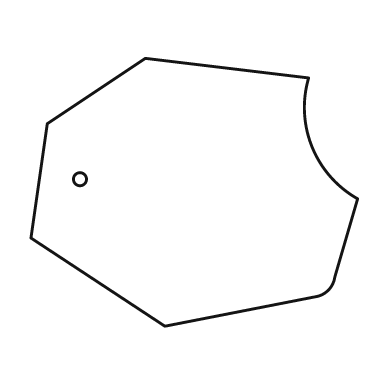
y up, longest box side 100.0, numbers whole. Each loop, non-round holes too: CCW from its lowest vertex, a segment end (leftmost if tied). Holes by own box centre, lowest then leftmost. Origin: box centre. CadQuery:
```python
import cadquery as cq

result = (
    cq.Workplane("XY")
    .moveTo(-9.0, -41.0)
    .lineTo(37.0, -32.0)
    .threePointArc((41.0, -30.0), (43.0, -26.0))
    .lineTo(50.0, -2.0)
    .threePointArc((36.0, 14.0), (35.0, 35.0))
    .lineTo(-15.0, 41.0)
    .lineTo(-45.0, 21.0)
    .lineTo(-50.0, -14.0)
    .close()
    .moveTo(-35.0, 4.0)
    .circle(2.0)
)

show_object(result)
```